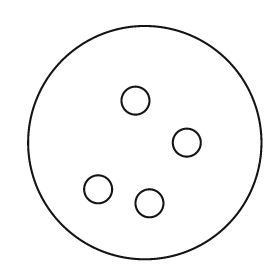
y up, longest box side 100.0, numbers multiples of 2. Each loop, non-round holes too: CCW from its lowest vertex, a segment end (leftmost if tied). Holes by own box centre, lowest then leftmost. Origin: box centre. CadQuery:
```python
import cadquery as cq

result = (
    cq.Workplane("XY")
    .moveTo(0.0, 0.0)
    .circle(50.0)
    .moveTo(2.0, -26.0)
    .circle(6.0)
    .moveTo(-20.0, -20.0)
    .circle(6.0)
    .moveTo(18.0, 0.0)
    .circle(6.0)
    .moveTo(-4.0, 18.0)
    .circle(6.0)
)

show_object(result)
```